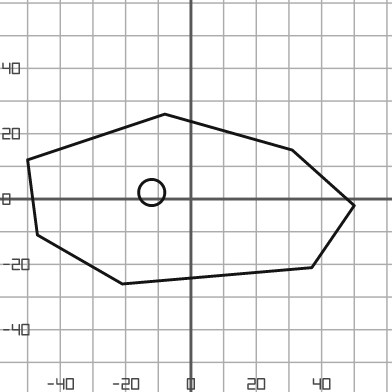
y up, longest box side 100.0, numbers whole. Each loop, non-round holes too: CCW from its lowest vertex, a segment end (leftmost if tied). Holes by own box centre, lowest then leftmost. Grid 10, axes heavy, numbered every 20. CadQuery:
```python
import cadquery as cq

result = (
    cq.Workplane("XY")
    .moveTo(-21.0, -26.0)
    .lineTo(37.0, -21.0)
    .lineTo(50.0, -2.0)
    .lineTo(31.0, 15.0)
    .lineTo(-8.0, 26.0)
    .lineTo(-50.0, 12.0)
    .lineTo(-47.0, -11.0)
    .close()
    .moveTo(-12.0, 2.0)
    .circle(4.0)
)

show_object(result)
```